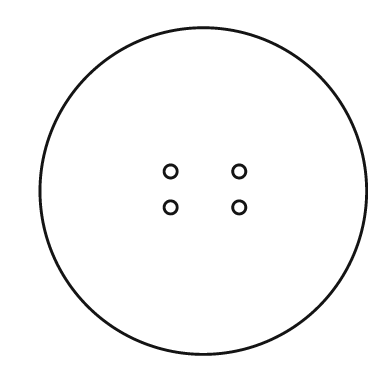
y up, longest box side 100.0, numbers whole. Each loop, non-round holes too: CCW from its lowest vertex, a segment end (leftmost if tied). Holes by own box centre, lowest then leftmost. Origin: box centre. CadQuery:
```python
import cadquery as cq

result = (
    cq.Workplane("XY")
    .moveTo(0.0, 0.0)
    .circle(50.0)
    .moveTo(-10.0, -5.0)
    .circle(2.0)
    .moveTo(11.0, -5.0)
    .circle(2.0)
    .moveTo(-10.0, 6.0)
    .circle(2.0)
    .moveTo(11.0, 6.0)
    .circle(2.0)
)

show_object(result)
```